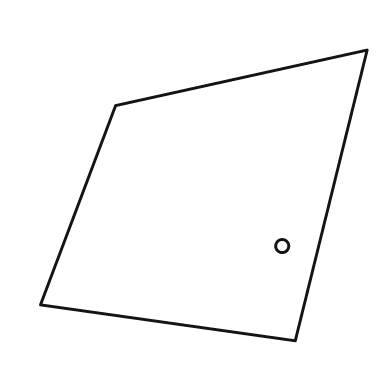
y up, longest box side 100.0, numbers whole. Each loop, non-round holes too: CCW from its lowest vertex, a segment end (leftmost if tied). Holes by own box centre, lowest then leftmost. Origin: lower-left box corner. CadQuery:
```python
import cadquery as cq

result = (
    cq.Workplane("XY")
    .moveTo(78.0, 0.0)
    .lineTo(100.0, 89.0)
    .lineTo(23.0, 72.0)
    .lineTo(0.0, 11.0)
    .close()
    .moveTo(74.0, 29.0)
    .circle(2.0)
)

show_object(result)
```